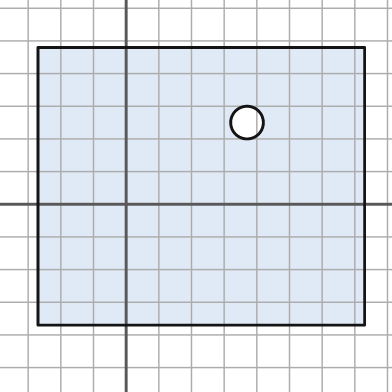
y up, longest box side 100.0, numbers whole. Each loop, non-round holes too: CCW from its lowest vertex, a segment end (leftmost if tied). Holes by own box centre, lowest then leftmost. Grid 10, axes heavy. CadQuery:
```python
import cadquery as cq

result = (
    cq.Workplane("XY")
    .moveTo(-27.0, -37.0)
    .lineTo(73.0, -37.0)
    .lineTo(73.0, 48.0)
    .lineTo(-27.0, 48.0)
    .close()
    .moveTo(37.0, 25.0)
    .circle(5.0)
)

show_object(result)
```